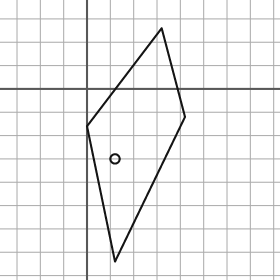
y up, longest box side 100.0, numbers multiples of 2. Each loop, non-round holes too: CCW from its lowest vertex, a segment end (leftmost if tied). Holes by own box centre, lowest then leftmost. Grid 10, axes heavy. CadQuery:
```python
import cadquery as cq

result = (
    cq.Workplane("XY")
    .moveTo(12.0, -74.0)
    .lineTo(42.0, -12.0)
    .lineTo(32.0, 26.0)
    .lineTo(0.0, -16.0)
    .close()
    .moveTo(12.0, -30.0)
    .circle(2.0)
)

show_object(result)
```